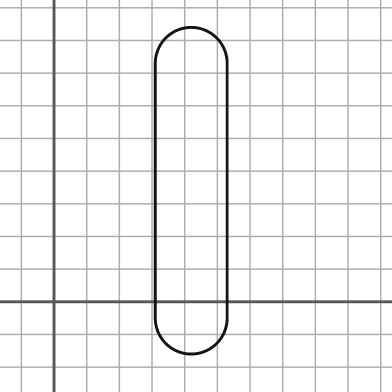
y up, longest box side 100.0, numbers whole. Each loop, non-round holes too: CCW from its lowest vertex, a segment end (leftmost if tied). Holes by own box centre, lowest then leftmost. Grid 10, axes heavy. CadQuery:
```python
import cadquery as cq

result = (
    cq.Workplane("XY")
    .moveTo(31.0, -5.0)
    .threePointArc((42.0, -16.0), (53.0, -5.0))
    .lineTo(53.0, 73.0)
    .threePointArc((42.0, 84.0), (31.0, 73.0))
    .close()
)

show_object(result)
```